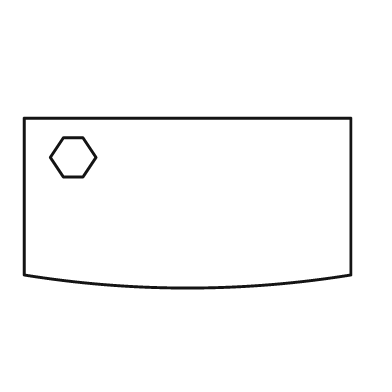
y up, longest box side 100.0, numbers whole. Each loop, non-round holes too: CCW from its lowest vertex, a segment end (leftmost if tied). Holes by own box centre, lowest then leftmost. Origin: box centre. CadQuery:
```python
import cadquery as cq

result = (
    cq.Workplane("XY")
    .moveTo(-50.0, -22.0)
    .threePointArc((0.0, -26.0), (50.0, -22.0))
    .lineTo(50.0, 26.0)
    .lineTo(-50.0, 26.0)
    .close()
    .moveTo(-38.0, 8.0)
    .lineTo(-32.0, 8.0)
    .lineTo(-28.0, 14.0)
    .lineTo(-32.0, 20.0)
    .lineTo(-38.0, 20.0)
    .lineTo(-42.0, 14.0)
    .close()
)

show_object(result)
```